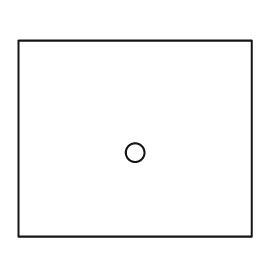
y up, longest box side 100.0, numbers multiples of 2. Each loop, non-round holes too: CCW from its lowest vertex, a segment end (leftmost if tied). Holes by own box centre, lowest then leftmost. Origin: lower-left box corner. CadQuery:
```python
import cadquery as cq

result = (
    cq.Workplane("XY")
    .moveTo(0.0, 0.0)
    .lineTo(100.0, 0.0)
    .lineTo(100.0, 84.0)
    .lineTo(0.0, 84.0)
    .close()
    .moveTo(50.0, 36.0)
    .circle(4.0)
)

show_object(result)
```